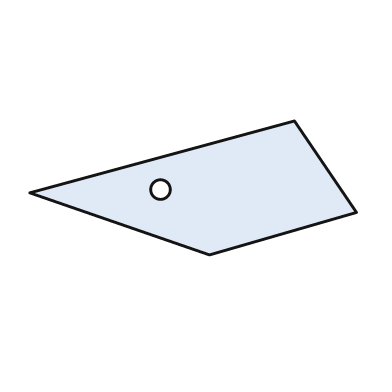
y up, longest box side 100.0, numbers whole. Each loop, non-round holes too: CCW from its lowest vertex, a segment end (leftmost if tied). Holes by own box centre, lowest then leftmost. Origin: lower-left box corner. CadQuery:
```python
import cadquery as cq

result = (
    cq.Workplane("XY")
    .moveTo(55.0, 0.0)
    .lineTo(100.0, 13.0)
    .lineTo(81.0, 41.0)
    .lineTo(0.0, 19.0)
    .close()
    .moveTo(40.0, 20.0)
    .circle(3.0)
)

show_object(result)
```